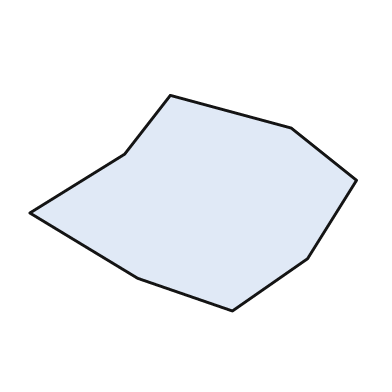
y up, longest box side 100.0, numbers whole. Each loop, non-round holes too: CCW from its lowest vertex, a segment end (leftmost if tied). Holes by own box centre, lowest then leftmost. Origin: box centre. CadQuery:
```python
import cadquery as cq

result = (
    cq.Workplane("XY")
    .moveTo(12.0, -33.0)
    .lineTo(35.0, -17.0)
    .lineTo(50.0, 7.0)
    .lineTo(30.0, 23.0)
    .lineTo(-7.0, 33.0)
    .lineTo(-21.0, 15.0)
    .lineTo(-50.0, -3.0)
    .lineTo(-17.0, -23.0)
    .close()
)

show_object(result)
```